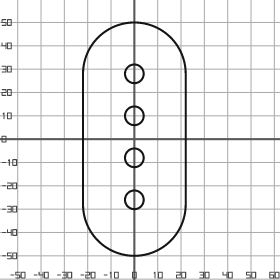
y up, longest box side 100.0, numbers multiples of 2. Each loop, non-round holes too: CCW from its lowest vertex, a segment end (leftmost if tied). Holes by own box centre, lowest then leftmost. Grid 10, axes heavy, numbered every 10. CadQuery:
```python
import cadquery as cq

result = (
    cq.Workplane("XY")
    .moveTo(-22.0, -28.0)
    .threePointArc((0.0, -50.0), (22.0, -28.0))
    .lineTo(22.0, 28.0)
    .threePointArc((0.0, 50.0), (-22.0, 28.0))
    .close()
    .moveTo(0.0, -26.0)
    .circle(4.0)
    .moveTo(0.0, -8.0)
    .circle(4.0)
    .moveTo(0.0, 10.0)
    .circle(4.0)
    .moveTo(0.0, 28.0)
    .circle(4.0)
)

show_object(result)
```